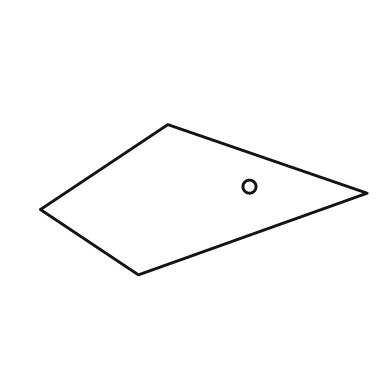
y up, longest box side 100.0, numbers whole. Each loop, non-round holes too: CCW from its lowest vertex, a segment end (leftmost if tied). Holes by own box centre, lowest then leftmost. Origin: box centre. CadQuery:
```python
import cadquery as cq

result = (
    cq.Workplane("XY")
    .moveTo(-20.0, -23.0)
    .lineTo(50.0, 2.0)
    .lineTo(-11.0, 23.0)
    .lineTo(-50.0, -3.0)
    .close()
    .moveTo(14.0, 4.0)
    .circle(2.0)
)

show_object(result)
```